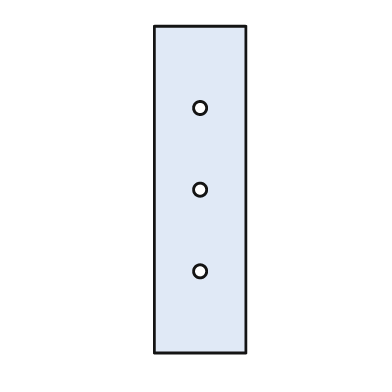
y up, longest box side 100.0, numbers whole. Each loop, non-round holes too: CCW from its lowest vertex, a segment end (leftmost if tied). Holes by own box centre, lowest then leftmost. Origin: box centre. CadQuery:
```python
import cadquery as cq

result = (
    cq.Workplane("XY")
    .moveTo(-14.0, -50.0)
    .lineTo(14.0, -50.0)
    .lineTo(14.0, 50.0)
    .lineTo(-14.0, 50.0)
    .close()
    .moveTo(0.0, -25.0)
    .circle(2.0)
    .moveTo(0.0, 0.0)
    .circle(2.0)
    .moveTo(0.0, 25.0)
    .circle(2.0)
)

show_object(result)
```